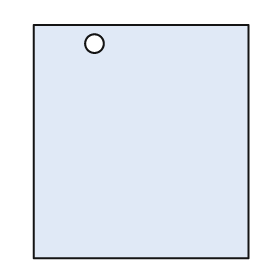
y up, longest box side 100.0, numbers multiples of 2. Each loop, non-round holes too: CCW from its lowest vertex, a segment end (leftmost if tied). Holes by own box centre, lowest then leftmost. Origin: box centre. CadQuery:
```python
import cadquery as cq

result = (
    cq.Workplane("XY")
    .moveTo(-46.0, -50.0)
    .lineTo(46.0, -50.0)
    .lineTo(46.0, 50.0)
    .lineTo(-46.0, 50.0)
    .close()
    .moveTo(-20.0, 42.0)
    .circle(4.0)
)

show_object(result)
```